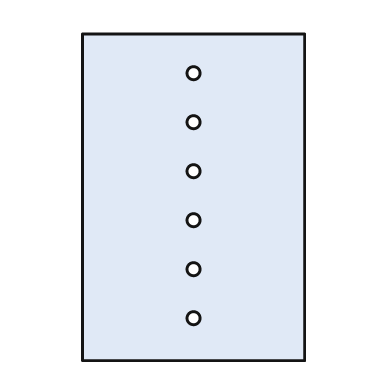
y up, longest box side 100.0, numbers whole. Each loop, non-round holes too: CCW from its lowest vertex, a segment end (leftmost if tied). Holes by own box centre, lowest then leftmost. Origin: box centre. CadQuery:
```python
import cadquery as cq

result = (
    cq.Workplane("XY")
    .moveTo(-34.0, -50.0)
    .lineTo(34.0, -50.0)
    .lineTo(34.0, 50.0)
    .lineTo(-34.0, 50.0)
    .close()
    .moveTo(0.0, -37.0)
    .circle(2.0)
    .moveTo(0.0, -22.0)
    .circle(2.0)
    .moveTo(0.0, -7.0)
    .circle(2.0)
    .moveTo(0.0, 8.0)
    .circle(2.0)
    .moveTo(0.0, 23.0)
    .circle(2.0)
    .moveTo(0.0, 38.0)
    .circle(2.0)
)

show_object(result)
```